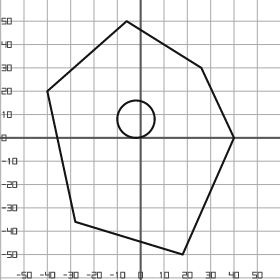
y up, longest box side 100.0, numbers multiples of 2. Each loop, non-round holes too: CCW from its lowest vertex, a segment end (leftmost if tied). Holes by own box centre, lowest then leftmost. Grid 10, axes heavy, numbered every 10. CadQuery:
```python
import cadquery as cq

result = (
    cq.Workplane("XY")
    .moveTo(18.0, -50.0)
    .lineTo(40.0, 0.0)
    .lineTo(26.0, 30.0)
    .lineTo(-6.0, 50.0)
    .lineTo(-40.0, 20.0)
    .lineTo(-28.0, -36.0)
    .close()
    .moveTo(-2.0, 8.0)
    .circle(8.0)
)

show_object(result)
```